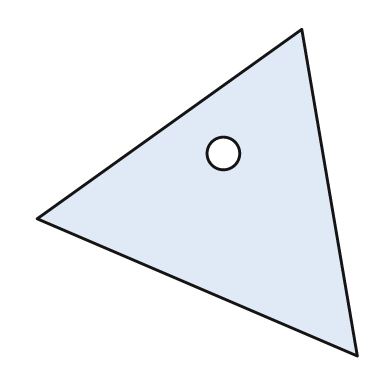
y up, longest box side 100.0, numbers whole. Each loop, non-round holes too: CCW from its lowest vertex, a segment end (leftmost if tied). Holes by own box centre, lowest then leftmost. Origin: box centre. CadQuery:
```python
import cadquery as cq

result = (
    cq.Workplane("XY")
    .moveTo(49.0, -50.0)
    .lineTo(32.0, 50.0)
    .lineTo(-49.0, -8.0)
    .close()
    .moveTo(8.0, 12.0)
    .circle(5.0)
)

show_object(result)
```